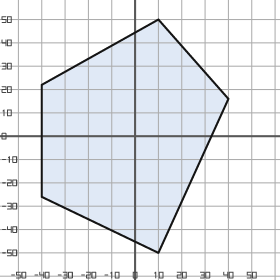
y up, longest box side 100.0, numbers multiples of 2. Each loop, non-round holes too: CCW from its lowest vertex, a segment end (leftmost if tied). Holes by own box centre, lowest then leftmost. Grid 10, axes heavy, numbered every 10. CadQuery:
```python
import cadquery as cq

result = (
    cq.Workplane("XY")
    .moveTo(10.0, -50.0)
    .lineTo(40.0, 16.0)
    .lineTo(10.0, 50.0)
    .lineTo(-40.0, 22.0)
    .lineTo(-40.0, -26.0)
    .close()
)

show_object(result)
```